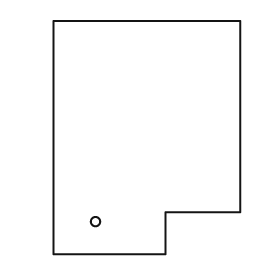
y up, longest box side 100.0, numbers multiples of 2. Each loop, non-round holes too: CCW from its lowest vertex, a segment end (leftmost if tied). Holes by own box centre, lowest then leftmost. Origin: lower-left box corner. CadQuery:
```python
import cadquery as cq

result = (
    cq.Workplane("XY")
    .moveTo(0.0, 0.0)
    .lineTo(48.0, 0.0)
    .lineTo(48.0, 18.0)
    .lineTo(80.0, 18.0)
    .lineTo(80.0, 100.0)
    .lineTo(0.0, 100.0)
    .close()
    .moveTo(18.0, 14.0)
    .circle(2.0)
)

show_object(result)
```